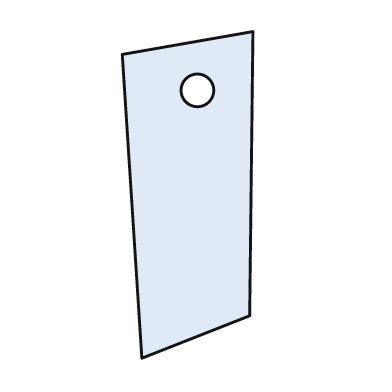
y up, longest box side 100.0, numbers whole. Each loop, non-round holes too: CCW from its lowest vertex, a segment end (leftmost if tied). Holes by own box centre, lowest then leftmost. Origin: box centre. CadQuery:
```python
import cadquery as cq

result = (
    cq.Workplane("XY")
    .moveTo(-14.0, -50.0)
    .lineTo(19.0, -37.0)
    .lineTo(20.0, 50.0)
    .lineTo(-20.0, 43.0)
    .close()
    .moveTo(3.0, 32.0)
    .circle(5.0)
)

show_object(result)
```